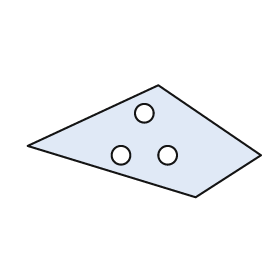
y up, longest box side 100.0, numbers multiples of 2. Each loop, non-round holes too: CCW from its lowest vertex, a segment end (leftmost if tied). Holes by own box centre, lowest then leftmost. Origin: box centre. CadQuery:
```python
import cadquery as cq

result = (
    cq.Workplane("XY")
    .moveTo(22.0, -24.0)
    .lineTo(50.0, -6.0)
    .lineTo(6.0, 24.0)
    .lineTo(-50.0, -2.0)
    .close()
    .moveTo(-10.0, -6.0)
    .circle(4.0)
    .moveTo(10.0, -6.0)
    .circle(4.0)
    .moveTo(0.0, 12.0)
    .circle(4.0)
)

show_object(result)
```